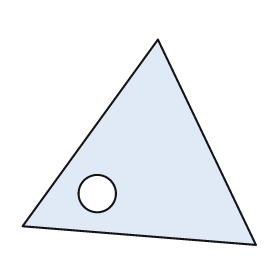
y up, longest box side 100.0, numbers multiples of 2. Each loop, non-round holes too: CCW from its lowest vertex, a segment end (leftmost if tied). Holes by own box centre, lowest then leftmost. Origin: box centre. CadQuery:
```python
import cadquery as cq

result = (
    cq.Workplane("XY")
    .moveTo(50.0, -44.0)
    .lineTo(8.0, 44.0)
    .lineTo(-50.0, -36.0)
    .close()
    .moveTo(-18.0, -22.0)
    .circle(8.0)
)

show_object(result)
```